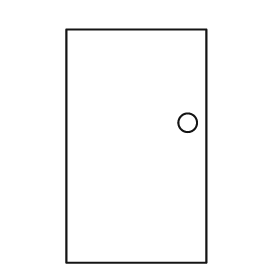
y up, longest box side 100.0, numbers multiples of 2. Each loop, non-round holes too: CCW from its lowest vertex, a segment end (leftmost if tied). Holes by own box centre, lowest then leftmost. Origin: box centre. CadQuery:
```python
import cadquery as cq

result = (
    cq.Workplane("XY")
    .moveTo(-30.0, -50.0)
    .lineTo(30.0, -50.0)
    .lineTo(30.0, 50.0)
    .lineTo(-30.0, 50.0)
    .close()
    .moveTo(22.0, 10.0)
    .circle(4.0)
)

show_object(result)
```